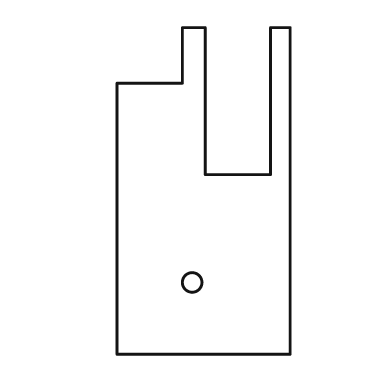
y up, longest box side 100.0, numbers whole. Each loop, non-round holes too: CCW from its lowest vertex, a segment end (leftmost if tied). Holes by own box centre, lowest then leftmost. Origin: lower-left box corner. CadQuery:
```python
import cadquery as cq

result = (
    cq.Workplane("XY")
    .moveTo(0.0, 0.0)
    .lineTo(53.0, 0.0)
    .lineTo(53.0, 100.0)
    .lineTo(47.0, 100.0)
    .lineTo(47.0, 55.0)
    .lineTo(27.0, 55.0)
    .lineTo(27.0, 100.0)
    .lineTo(20.0, 100.0)
    .lineTo(20.0, 83.0)
    .lineTo(0.0, 83.0)
    .close()
    .moveTo(23.0, 22.0)
    .circle(3.0)
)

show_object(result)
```